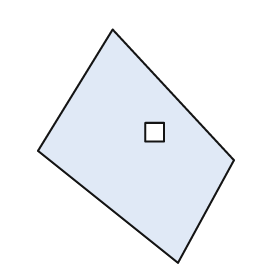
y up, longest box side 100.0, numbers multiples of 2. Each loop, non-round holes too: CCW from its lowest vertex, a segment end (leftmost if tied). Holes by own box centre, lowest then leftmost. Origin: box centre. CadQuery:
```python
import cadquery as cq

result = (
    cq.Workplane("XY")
    .moveTo(18.0, -50.0)
    .lineTo(42.0, -6.0)
    .lineTo(-10.0, 50.0)
    .lineTo(-42.0, -2.0)
    .close()
    .moveTo(4.0, 2.0)
    .lineTo(12.0, 2.0)
    .lineTo(12.0, 10.0)
    .lineTo(4.0, 10.0)
    .close()
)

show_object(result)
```